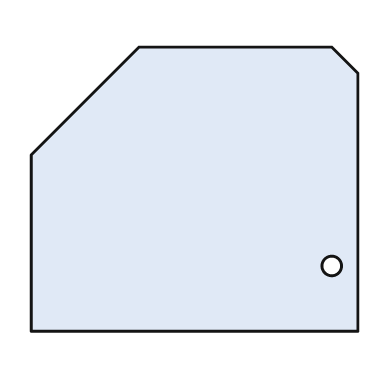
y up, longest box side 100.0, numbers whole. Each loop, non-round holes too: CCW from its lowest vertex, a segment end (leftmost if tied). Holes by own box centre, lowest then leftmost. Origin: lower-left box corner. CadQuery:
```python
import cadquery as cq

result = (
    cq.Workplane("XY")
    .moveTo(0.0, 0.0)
    .lineTo(100.0, 0.0)
    .lineTo(100.0, 79.0)
    .lineTo(92.0, 87.0)
    .lineTo(33.0, 87.0)
    .lineTo(0.0, 54.0)
    .close()
    .moveTo(92.0, 20.0)
    .circle(3.0)
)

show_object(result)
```